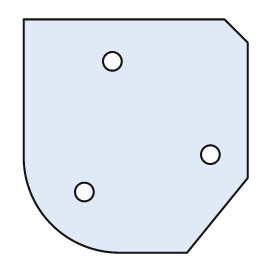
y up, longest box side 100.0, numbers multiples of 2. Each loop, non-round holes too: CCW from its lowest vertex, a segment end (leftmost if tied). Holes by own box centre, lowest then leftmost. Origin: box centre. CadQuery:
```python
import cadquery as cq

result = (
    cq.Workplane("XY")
    .moveTo(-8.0, -50.0)
    .lineTo(22.0, -50.0)
    .lineTo(48.0, -18.0)
    .lineTo(48.0, 40.0)
    .lineTo(38.0, 50.0)
    .lineTo(-48.0, 50.0)
    .lineTo(-48.0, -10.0)
    .threePointArc((-36.0, -38.0), (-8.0, -50.0))
    .close()
    .moveTo(-22.0, -24.0)
    .circle(4.0)
    .moveTo(32.0, -8.0)
    .circle(4.0)
    .moveTo(-10.0, 32.0)
    .circle(4.0)
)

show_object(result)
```